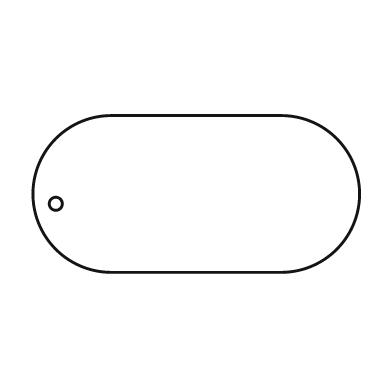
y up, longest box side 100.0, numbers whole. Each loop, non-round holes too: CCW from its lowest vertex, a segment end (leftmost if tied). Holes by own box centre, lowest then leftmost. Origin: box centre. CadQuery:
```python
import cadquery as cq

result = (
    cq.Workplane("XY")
    .moveTo(-26.0, -24.0)
    .lineTo(26.0, -24.0)
    .threePointArc((50.0, 0.0), (26.0, 24.0))
    .lineTo(-26.0, 24.0)
    .threePointArc((-50.0, 0.0), (-26.0, -24.0))
    .close()
    .moveTo(-43.0, -3.0)
    .circle(2.0)
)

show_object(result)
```